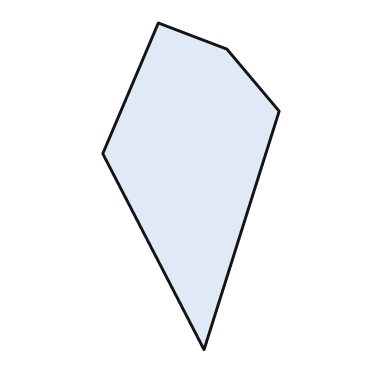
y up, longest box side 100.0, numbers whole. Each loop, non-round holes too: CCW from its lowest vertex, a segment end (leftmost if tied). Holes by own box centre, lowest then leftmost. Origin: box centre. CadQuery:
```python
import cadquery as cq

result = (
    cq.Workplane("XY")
    .moveTo(4.0, -50.0)
    .lineTo(27.0, 23.0)
    .lineTo(11.0, 42.0)
    .lineTo(-10.0, 50.0)
    .lineTo(-27.0, 10.0)
    .close()
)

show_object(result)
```